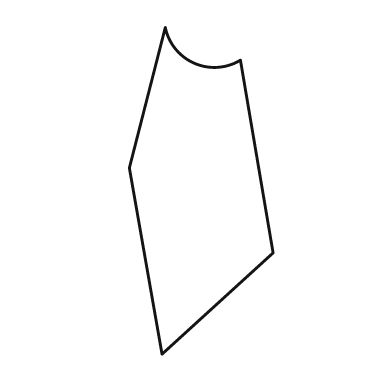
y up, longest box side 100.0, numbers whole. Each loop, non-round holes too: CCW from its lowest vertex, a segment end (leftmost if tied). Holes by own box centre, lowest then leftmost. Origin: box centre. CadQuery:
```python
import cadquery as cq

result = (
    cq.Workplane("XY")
    .moveTo(-12.0, -50.0)
    .lineTo(22.0, -19.0)
    .lineTo(12.0, 40.0)
    .threePointArc((-2.0, 39.0), (-11.0, 50.0))
    .lineTo(-22.0, 7.0)
    .close()
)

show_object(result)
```